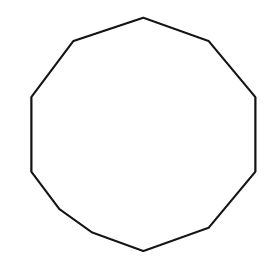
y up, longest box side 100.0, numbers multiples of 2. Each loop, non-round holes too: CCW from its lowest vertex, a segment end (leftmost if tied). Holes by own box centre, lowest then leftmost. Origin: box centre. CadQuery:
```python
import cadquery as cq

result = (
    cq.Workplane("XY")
    .moveTo(0.0, -50.0)
    .lineTo(28.0, -40.0)
    .lineTo(48.0, -16.0)
    .lineTo(48.0, 16.0)
    .lineTo(28.0, 40.0)
    .lineTo(0.0, 50.0)
    .lineTo(-30.0, 40.0)
    .lineTo(-48.0, 16.0)
    .lineTo(-48.0, -16.0)
    .lineTo(-36.0, -32.0)
    .lineTo(-22.0, -42.0)
    .close()
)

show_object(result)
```